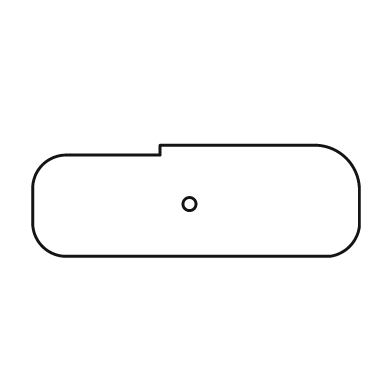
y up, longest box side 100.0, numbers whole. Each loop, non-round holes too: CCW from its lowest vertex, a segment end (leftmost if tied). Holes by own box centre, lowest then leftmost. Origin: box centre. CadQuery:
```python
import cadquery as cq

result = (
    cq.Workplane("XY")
    .moveTo(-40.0, -17.0)
    .lineTo(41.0, -17.0)
    .threePointArc((47.0, -14.0), (50.0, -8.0))
    .lineTo(50.0, 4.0)
    .threePointArc((46.0, 13.0), (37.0, 17.0))
    .lineTo(-11.0, 17.0)
    .lineTo(-11.0, 14.0)
    .lineTo(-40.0, 14.0)
    .threePointArc((-47.0, 11.0), (-50.0, 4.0))
    .lineTo(-50.0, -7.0)
    .threePointArc((-47.0, -14.0), (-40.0, -17.0))
    .close()
    .moveTo(-2.0, -1.0)
    .circle(2.0)
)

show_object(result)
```